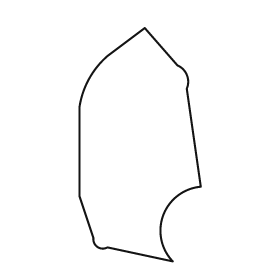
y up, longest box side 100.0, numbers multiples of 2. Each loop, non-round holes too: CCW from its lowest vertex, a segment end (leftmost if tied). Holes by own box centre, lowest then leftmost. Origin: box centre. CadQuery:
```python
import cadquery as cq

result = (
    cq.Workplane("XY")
    .moveTo(14.0, -50.0)
    .threePointArc((10.0, -30.0), (26.0, -18.0))
    .lineTo(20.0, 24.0)
    .threePointArc((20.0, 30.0), (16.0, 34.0))
    .lineTo(2.0, 50.0)
    .lineTo(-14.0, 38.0)
    .threePointArc((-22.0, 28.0), (-26.0, 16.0))
    .lineTo(-26.0, -22.0)
    .lineTo(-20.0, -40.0)
    .threePointArc((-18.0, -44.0), (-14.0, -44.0))
    .close()
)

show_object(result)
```